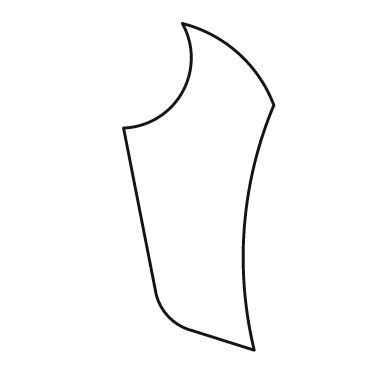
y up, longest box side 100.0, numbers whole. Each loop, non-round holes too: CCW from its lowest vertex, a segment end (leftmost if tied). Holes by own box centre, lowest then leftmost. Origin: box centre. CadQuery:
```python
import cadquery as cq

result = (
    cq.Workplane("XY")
    .moveTo(17.0, -50.0)
    .threePointArc((14.0, -12.0), (23.0, 25.0))
    .threePointArc((12.0, 41.0), (-5.0, 50.0))
    .threePointArc((-5.0, 29.0), (-23.0, 18.0))
    .lineTo(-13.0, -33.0)
    .threePointArc((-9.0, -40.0), (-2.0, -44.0))
    .close()
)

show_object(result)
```